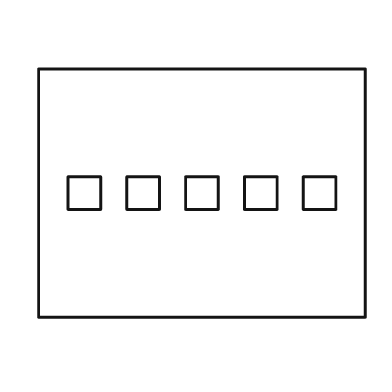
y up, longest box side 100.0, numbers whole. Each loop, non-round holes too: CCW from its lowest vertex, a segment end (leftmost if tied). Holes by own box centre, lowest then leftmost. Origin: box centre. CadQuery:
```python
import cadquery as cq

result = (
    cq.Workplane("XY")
    .moveTo(-50.0, -38.0)
    .lineTo(50.0, -38.0)
    .lineTo(50.0, 38.0)
    .lineTo(-50.0, 38.0)
    .close()
    .moveTo(-41.0, -5.0)
    .lineTo(-31.0, -5.0)
    .lineTo(-31.0, 5.0)
    .lineTo(-41.0, 5.0)
    .close()
    .moveTo(-23.0, -5.0)
    .lineTo(-13.0, -5.0)
    .lineTo(-13.0, 5.0)
    .lineTo(-23.0, 5.0)
    .close()
    .moveTo(-5.0, -5.0)
    .lineTo(5.0, -5.0)
    .lineTo(5.0, 5.0)
    .lineTo(-5.0, 5.0)
    .close()
    .moveTo(13.0, -5.0)
    .lineTo(23.0, -5.0)
    .lineTo(23.0, 5.0)
    .lineTo(13.0, 5.0)
    .close()
    .moveTo(31.0, -5.0)
    .lineTo(41.0, -5.0)
    .lineTo(41.0, 5.0)
    .lineTo(31.0, 5.0)
    .close()
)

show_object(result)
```